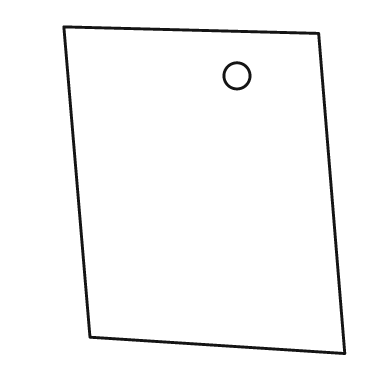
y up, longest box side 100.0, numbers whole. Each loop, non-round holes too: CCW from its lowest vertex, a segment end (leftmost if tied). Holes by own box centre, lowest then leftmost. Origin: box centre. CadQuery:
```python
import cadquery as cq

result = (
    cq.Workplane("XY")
    .moveTo(43.0, -50.0)
    .lineTo(35.0, 48.0)
    .lineTo(-43.0, 50.0)
    .lineTo(-35.0, -45.0)
    .close()
    .moveTo(10.0, 35.0)
    .circle(4.0)
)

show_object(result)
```